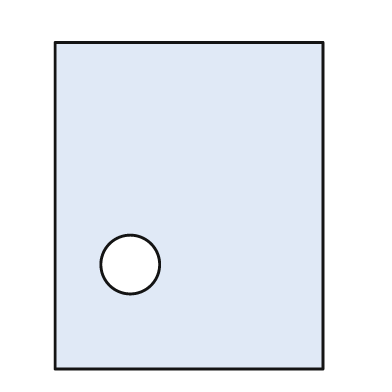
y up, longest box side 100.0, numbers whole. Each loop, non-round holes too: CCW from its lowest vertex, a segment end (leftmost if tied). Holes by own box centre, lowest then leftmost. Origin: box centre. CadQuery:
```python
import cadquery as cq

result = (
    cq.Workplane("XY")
    .moveTo(-41.0, -50.0)
    .lineTo(41.0, -50.0)
    .lineTo(41.0, 50.0)
    .lineTo(-41.0, 50.0)
    .close()
    .moveTo(-18.0, -18.0)
    .circle(9.0)
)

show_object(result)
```